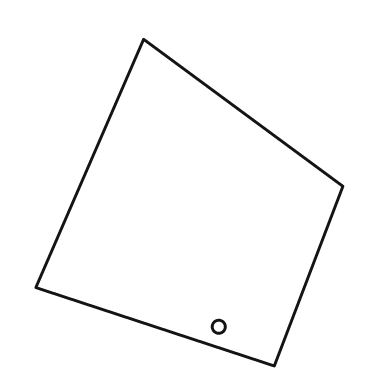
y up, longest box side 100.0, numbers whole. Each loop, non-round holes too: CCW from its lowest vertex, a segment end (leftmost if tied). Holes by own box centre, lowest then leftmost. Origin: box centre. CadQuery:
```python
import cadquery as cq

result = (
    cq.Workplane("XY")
    .moveTo(26.0, -50.0)
    .lineTo(47.0, 5.0)
    .lineTo(-14.0, 50.0)
    .lineTo(-47.0, -26.0)
    .close()
    .moveTo(9.0, -38.0)
    .circle(2.0)
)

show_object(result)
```